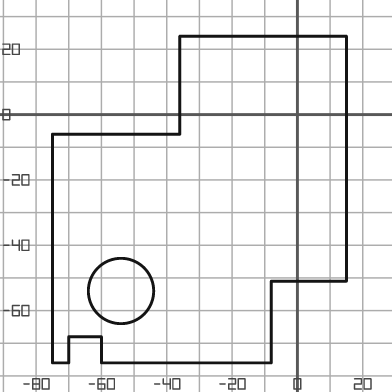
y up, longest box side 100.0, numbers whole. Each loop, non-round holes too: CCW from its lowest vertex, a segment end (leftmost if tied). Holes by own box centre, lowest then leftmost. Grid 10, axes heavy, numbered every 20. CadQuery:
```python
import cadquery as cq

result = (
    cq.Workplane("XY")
    .moveTo(-75.0, -76.0)
    .lineTo(-70.0, -76.0)
    .lineTo(-70.0, -68.0)
    .lineTo(-60.0, -68.0)
    .lineTo(-60.0, -76.0)
    .lineTo(-8.0, -76.0)
    .lineTo(-8.0, -51.0)
    .lineTo(15.0, -51.0)
    .lineTo(15.0, 24.0)
    .lineTo(-36.0, 24.0)
    .lineTo(-36.0, -6.0)
    .lineTo(-75.0, -6.0)
    .close()
    .moveTo(-54.0, -54.0)
    .circle(10.0)
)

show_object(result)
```